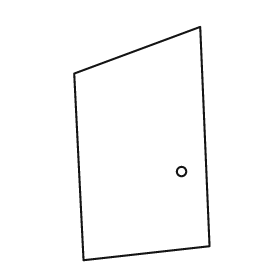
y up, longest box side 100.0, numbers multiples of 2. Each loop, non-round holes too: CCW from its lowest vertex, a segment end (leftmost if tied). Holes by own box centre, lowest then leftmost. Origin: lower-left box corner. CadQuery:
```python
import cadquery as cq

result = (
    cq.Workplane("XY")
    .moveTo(4.0, 0.0)
    .lineTo(58.0, 6.0)
    .lineTo(54.0, 100.0)
    .lineTo(0.0, 80.0)
    .close()
    .moveTo(46.0, 38.0)
    .circle(2.0)
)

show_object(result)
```